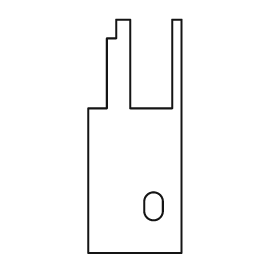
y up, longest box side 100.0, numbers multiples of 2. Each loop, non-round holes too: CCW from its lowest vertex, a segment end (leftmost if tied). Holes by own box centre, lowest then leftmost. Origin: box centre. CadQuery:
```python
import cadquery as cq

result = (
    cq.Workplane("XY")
    .moveTo(-20.0, -50.0)
    .lineTo(20.0, -50.0)
    .lineTo(20.0, 50.0)
    .lineTo(16.0, 50.0)
    .lineTo(16.0, 12.0)
    .lineTo(-2.0, 12.0)
    .lineTo(-2.0, 50.0)
    .lineTo(-8.0, 50.0)
    .lineTo(-8.0, 42.0)
    .lineTo(-12.0, 42.0)
    .lineTo(-12.0, 12.0)
    .lineTo(-20.0, 12.0)
    .close()
    .moveTo(4.0, -32.0)
    .threePointArc((8.0, -36.0), (12.0, -32.0))
    .lineTo(12.0, -28.0)
    .threePointArc((8.0, -24.0), (4.0, -28.0))
    .close()
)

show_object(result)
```